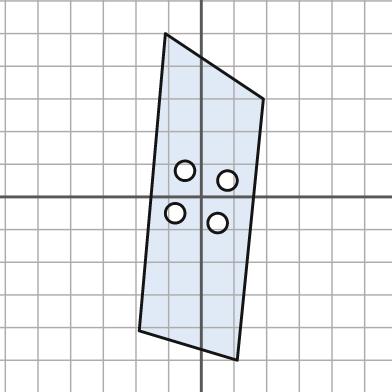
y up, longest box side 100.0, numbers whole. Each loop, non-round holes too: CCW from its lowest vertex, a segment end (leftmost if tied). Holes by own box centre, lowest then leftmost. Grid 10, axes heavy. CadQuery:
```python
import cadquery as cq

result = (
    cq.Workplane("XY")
    .moveTo(11.0, -50.0)
    .lineTo(19.0, 30.0)
    .lineTo(-11.0, 50.0)
    .lineTo(-19.0, -41.0)
    .close()
    .moveTo(5.0, -8.0)
    .circle(3.0)
    .moveTo(-8.0, -5.0)
    .circle(3.0)
    .moveTo(8.0, 5.0)
    .circle(3.0)
    .moveTo(-5.0, 8.0)
    .circle(3.0)
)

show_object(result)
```